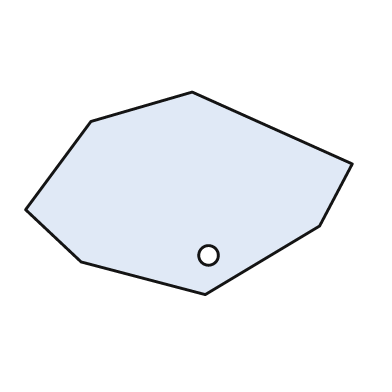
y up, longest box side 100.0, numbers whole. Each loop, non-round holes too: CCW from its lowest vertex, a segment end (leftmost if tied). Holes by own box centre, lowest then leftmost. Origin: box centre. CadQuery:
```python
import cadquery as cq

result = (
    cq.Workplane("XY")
    .moveTo(5.0, -31.0)
    .lineTo(40.0, -10.0)
    .lineTo(50.0, 9.0)
    .lineTo(1.0, 31.0)
    .lineTo(-30.0, 22.0)
    .lineTo(-50.0, -5.0)
    .lineTo(-33.0, -21.0)
    .close()
    .moveTo(6.0, -19.0)
    .circle(3.0)
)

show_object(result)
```